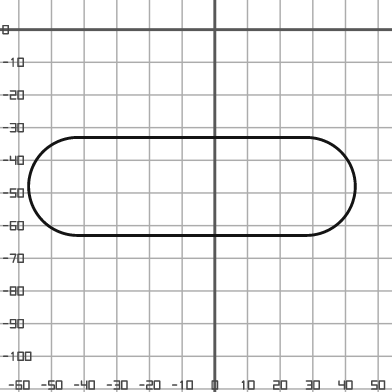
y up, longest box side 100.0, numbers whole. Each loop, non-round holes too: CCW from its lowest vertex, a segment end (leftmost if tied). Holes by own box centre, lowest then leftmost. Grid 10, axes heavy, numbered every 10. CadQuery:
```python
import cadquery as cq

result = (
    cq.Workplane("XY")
    .moveTo(-42.0, -63.0)
    .lineTo(28.0, -63.0)
    .threePointArc((43.0, -48.0), (28.0, -33.0))
    .lineTo(-42.0, -33.0)
    .threePointArc((-57.0, -48.0), (-42.0, -63.0))
    .close()
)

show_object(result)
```